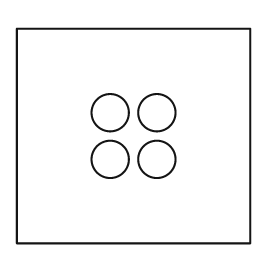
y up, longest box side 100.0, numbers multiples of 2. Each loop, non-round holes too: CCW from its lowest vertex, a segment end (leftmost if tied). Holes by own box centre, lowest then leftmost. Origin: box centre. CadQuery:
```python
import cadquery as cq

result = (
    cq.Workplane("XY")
    .moveTo(-50.0, -46.0)
    .lineTo(50.0, -46.0)
    .lineTo(50.0, 46.0)
    .lineTo(-50.0, 46.0)
    .close()
    .moveTo(-10.0, -10.0)
    .circle(8.0)
    .moveTo(10.0, -10.0)
    .circle(8.0)
    .moveTo(-10.0, 10.0)
    .circle(8.0)
    .moveTo(10.0, 10.0)
    .circle(8.0)
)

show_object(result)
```